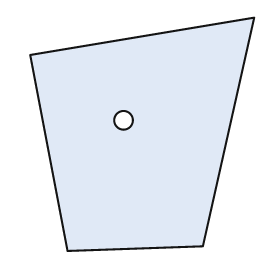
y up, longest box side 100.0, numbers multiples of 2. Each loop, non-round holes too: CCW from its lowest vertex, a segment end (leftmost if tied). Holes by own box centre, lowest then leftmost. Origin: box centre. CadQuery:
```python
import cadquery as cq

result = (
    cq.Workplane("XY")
    .moveTo(-32.0, -50.0)
    .lineTo(26.0, -48.0)
    .lineTo(48.0, 50.0)
    .lineTo(-48.0, 34.0)
    .close()
    .moveTo(-8.0, 6.0)
    .circle(4.0)
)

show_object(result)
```